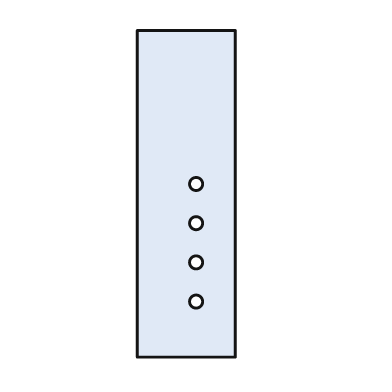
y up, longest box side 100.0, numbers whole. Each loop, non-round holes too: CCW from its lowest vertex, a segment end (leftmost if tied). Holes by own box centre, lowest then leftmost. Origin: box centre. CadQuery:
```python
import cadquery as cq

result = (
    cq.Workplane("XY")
    .moveTo(-15.0, -50.0)
    .lineTo(15.0, -50.0)
    .lineTo(15.0, 50.0)
    .lineTo(-15.0, 50.0)
    .close()
    .moveTo(3.0, -33.0)
    .circle(2.0)
    .moveTo(3.0, -21.0)
    .circle(2.0)
    .moveTo(3.0, -9.0)
    .circle(2.0)
    .moveTo(3.0, 3.0)
    .circle(2.0)
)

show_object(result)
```